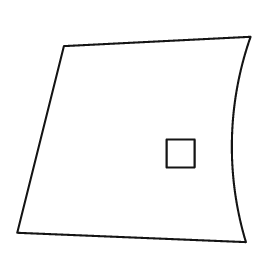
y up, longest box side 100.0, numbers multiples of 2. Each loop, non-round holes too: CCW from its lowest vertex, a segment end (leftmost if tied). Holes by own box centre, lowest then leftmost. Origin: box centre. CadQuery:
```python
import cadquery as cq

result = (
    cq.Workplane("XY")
    .moveTo(48.0, -44.0)
    .threePointArc((42.0, 0.0), (50.0, 44.0))
    .lineTo(-30.0, 40.0)
    .lineTo(-50.0, -40.0)
    .close()
    .moveTo(14.0, -12.0)
    .lineTo(26.0, -12.0)
    .lineTo(26.0, 0.0)
    .lineTo(14.0, 0.0)
    .close()
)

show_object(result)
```